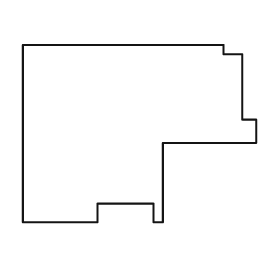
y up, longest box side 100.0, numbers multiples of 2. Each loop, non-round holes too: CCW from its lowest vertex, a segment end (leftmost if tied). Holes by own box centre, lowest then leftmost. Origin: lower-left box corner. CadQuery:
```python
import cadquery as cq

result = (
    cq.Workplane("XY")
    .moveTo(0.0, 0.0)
    .lineTo(32.0, 0.0)
    .lineTo(32.0, 8.0)
    .lineTo(56.0, 8.0)
    .lineTo(56.0, 0.0)
    .lineTo(60.0, 0.0)
    .lineTo(60.0, 34.0)
    .lineTo(100.0, 34.0)
    .lineTo(100.0, 44.0)
    .lineTo(94.0, 44.0)
    .lineTo(94.0, 72.0)
    .lineTo(86.0, 72.0)
    .lineTo(86.0, 76.0)
    .lineTo(0.0, 76.0)
    .close()
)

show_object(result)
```